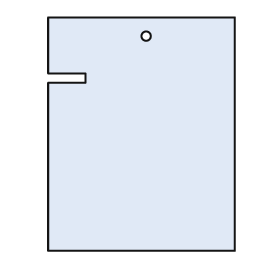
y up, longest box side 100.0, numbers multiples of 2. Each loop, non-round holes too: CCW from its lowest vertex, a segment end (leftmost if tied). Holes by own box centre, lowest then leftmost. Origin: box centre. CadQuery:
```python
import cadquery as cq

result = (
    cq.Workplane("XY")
    .moveTo(-40.0, -50.0)
    .lineTo(40.0, -50.0)
    .lineTo(40.0, 50.0)
    .lineTo(-40.0, 50.0)
    .lineTo(-40.0, 26.0)
    .lineTo(-24.0, 26.0)
    .lineTo(-24.0, 22.0)
    .lineTo(-40.0, 22.0)
    .close()
    .moveTo(2.0, 42.0)
    .circle(2.0)
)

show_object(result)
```